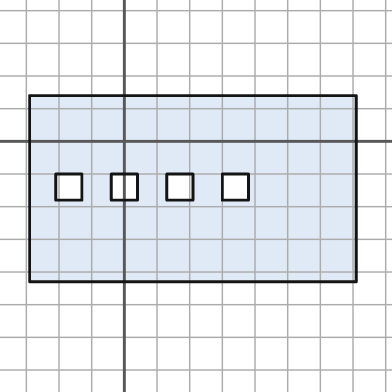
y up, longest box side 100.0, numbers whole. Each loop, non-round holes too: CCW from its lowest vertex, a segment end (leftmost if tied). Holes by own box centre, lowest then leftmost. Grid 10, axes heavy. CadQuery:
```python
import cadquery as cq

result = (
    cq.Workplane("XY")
    .moveTo(-29.0, -43.0)
    .lineTo(71.0, -43.0)
    .lineTo(71.0, 14.0)
    .lineTo(-29.0, 14.0)
    .close()
    .moveTo(-21.0, -18.0)
    .lineTo(-13.0, -18.0)
    .lineTo(-13.0, -10.0)
    .lineTo(-21.0, -10.0)
    .close()
    .moveTo(-4.0, -18.0)
    .lineTo(4.0, -18.0)
    .lineTo(4.0, -10.0)
    .lineTo(-4.0, -10.0)
    .close()
    .moveTo(13.0, -18.0)
    .lineTo(21.0, -18.0)
    .lineTo(21.0, -10.0)
    .lineTo(13.0, -10.0)
    .close()
    .moveTo(30.0, -18.0)
    .lineTo(38.0, -18.0)
    .lineTo(38.0, -10.0)
    .lineTo(30.0, -10.0)
    .close()
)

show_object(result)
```